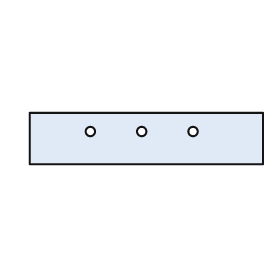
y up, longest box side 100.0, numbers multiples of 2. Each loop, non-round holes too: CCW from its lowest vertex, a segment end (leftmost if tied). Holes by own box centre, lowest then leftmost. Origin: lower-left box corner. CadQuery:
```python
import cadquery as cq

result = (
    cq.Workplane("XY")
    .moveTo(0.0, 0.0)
    .lineTo(100.0, 0.0)
    .lineTo(100.0, 22.0)
    .lineTo(0.0, 22.0)
    .close()
    .moveTo(26.0, 14.0)
    .circle(2.0)
    .moveTo(48.0, 14.0)
    .circle(2.0)
    .moveTo(70.0, 14.0)
    .circle(2.0)
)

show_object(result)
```